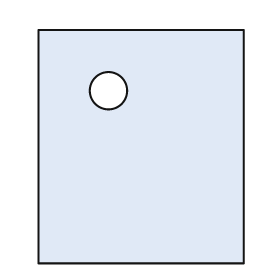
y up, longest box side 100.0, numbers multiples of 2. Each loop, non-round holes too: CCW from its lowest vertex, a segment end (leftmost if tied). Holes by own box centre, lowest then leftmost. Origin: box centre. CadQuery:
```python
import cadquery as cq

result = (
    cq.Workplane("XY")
    .moveTo(-44.0, -50.0)
    .lineTo(44.0, -50.0)
    .lineTo(44.0, 50.0)
    .lineTo(-44.0, 50.0)
    .close()
    .moveTo(-14.0, 24.0)
    .circle(8.0)
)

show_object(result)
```